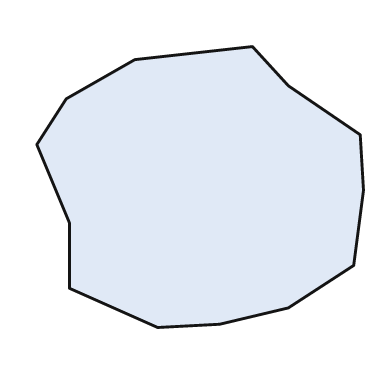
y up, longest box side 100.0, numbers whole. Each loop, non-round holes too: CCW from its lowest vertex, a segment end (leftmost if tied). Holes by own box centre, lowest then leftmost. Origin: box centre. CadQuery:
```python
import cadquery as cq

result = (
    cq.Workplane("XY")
    .moveTo(-13.0, -43.0)
    .lineTo(6.0, -42.0)
    .lineTo(27.0, -37.0)
    .lineTo(47.0, -24.0)
    .lineTo(50.0, -1.0)
    .lineTo(49.0, 16.0)
    .lineTo(27.0, 31.0)
    .lineTo(16.0, 43.0)
    .lineTo(-20.0, 39.0)
    .lineTo(-41.0, 27.0)
    .lineTo(-50.0, 13.0)
    .lineTo(-40.0, -11.0)
    .lineTo(-40.0, -31.0)
    .close()
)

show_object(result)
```